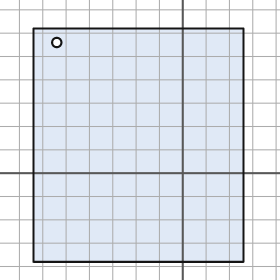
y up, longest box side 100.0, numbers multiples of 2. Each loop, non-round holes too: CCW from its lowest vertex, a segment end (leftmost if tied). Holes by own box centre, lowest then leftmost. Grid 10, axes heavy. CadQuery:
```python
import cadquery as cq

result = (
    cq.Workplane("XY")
    .moveTo(-64.0, -38.0)
    .lineTo(26.0, -38.0)
    .lineTo(26.0, 62.0)
    .lineTo(-64.0, 62.0)
    .close()
    .moveTo(-54.0, 56.0)
    .circle(2.0)
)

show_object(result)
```